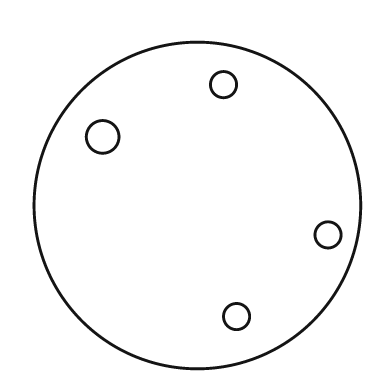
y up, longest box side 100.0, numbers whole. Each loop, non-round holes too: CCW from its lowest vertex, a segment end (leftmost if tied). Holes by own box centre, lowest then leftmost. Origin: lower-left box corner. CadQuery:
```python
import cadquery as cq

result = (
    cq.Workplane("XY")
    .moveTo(50.0, 50.0)
    .circle(50.0)
    .moveTo(62.0, 16.0)
    .circle(4.0)
    .moveTo(90.0, 41.0)
    .circle(4.0)
    .moveTo(21.0, 71.0)
    .circle(5.0)
    .moveTo(58.0, 87.0)
    .circle(4.0)
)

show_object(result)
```